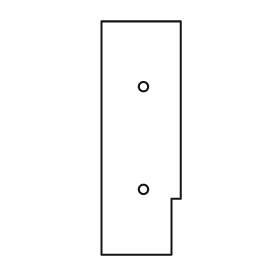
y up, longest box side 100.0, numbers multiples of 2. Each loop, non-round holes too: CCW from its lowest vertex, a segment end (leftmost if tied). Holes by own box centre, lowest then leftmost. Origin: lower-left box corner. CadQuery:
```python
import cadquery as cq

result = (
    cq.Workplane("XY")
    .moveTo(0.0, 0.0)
    .lineTo(30.0, 0.0)
    .lineTo(30.0, 24.0)
    .lineTo(34.0, 24.0)
    .lineTo(34.0, 100.0)
    .lineTo(0.0, 100.0)
    .close()
    .moveTo(18.0, 28.0)
    .circle(2.0)
    .moveTo(18.0, 72.0)
    .circle(2.0)
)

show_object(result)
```